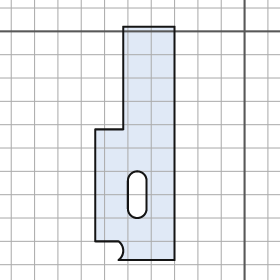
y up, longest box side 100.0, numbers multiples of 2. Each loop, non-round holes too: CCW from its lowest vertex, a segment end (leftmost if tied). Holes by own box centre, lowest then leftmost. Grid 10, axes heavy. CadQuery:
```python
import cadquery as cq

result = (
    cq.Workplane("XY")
    .moveTo(-54.0, -98.0)
    .lineTo(-30.0, -98.0)
    .lineTo(-30.0, 2.0)
    .lineTo(-52.0, 2.0)
    .lineTo(-52.0, -42.0)
    .lineTo(-64.0, -42.0)
    .lineTo(-64.0, -90.0)
    .lineTo(-54.0, -90.0)
    .threePointArc((-52.0, -94.0), (-54.0, -98.0))
    .close()
    .moveTo(-50.0, -76.0)
    .threePointArc((-46.0, -80.0), (-42.0, -76.0))
    .lineTo(-42.0, -64.0)
    .threePointArc((-46.0, -60.0), (-50.0, -64.0))
    .close()
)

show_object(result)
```